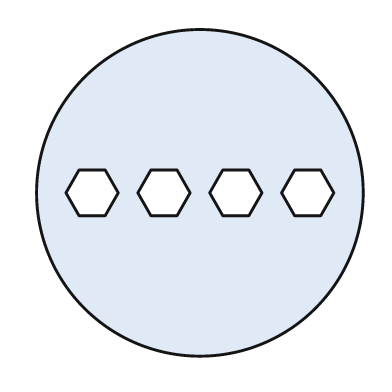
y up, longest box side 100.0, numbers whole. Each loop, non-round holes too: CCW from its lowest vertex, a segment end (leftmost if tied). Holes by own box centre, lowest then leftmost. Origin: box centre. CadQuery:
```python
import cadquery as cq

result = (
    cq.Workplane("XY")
    .moveTo(0.0, 0.0)
    .circle(50.0)
    .moveTo(-37.0, -7.0)
    .lineTo(-29.0, -7.0)
    .lineTo(-25.0, 0.0)
    .lineTo(-29.0, 7.0)
    .lineTo(-37.0, 7.0)
    .lineTo(-41.0, 0.0)
    .close()
    .moveTo(-15.0, -7.0)
    .lineTo(-7.0, -7.0)
    .lineTo(-3.0, 0.0)
    .lineTo(-7.0, 7.0)
    .lineTo(-15.0, 7.0)
    .lineTo(-19.0, 0.0)
    .close()
    .moveTo(7.0, -7.0)
    .lineTo(15.0, -7.0)
    .lineTo(19.0, 0.0)
    .lineTo(15.0, 7.0)
    .lineTo(7.0, 7.0)
    .lineTo(3.0, 0.0)
    .close()
    .moveTo(29.0, -7.0)
    .lineTo(37.0, -7.0)
    .lineTo(41.0, 0.0)
    .lineTo(37.0, 7.0)
    .lineTo(29.0, 7.0)
    .lineTo(25.0, 0.0)
    .close()
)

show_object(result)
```